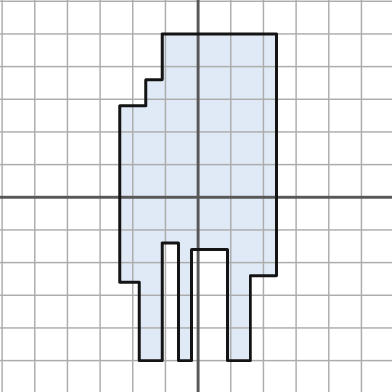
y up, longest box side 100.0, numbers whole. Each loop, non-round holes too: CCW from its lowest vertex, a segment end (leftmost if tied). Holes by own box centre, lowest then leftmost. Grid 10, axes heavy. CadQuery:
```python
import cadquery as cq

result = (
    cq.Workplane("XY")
    .moveTo(-18.0, -50.0)
    .lineTo(-11.0, -50.0)
    .lineTo(-11.0, -14.0)
    .lineTo(-6.0, -14.0)
    .lineTo(-6.0, -50.0)
    .lineTo(-2.0, -50.0)
    .lineTo(-2.0, -16.0)
    .lineTo(9.0, -16.0)
    .lineTo(9.0, -50.0)
    .lineTo(16.0, -50.0)
    .lineTo(16.0, -24.0)
    .lineTo(24.0, -24.0)
    .lineTo(24.0, 50.0)
    .lineTo(-11.0, 50.0)
    .lineTo(-11.0, 36.0)
    .lineTo(-16.0, 36.0)
    .lineTo(-16.0, 28.0)
    .lineTo(-24.0, 28.0)
    .lineTo(-24.0, -26.0)
    .lineTo(-18.0, -26.0)
    .close()
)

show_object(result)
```